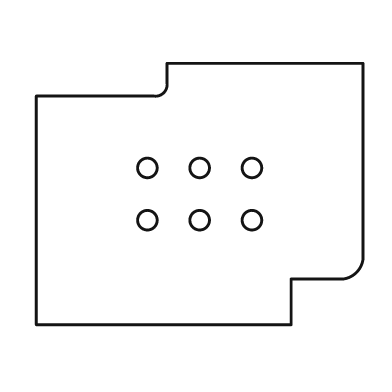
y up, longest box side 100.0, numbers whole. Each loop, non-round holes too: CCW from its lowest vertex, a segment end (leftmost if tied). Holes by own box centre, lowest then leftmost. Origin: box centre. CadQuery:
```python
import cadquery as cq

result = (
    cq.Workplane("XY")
    .moveTo(-50.0, -40.0)
    .lineTo(28.0, -40.0)
    .lineTo(28.0, -26.0)
    .lineTo(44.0, -26.0)
    .threePointArc((48.0, -24.0), (50.0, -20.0))
    .lineTo(50.0, 40.0)
    .lineTo(-10.0, 40.0)
    .lineTo(-10.0, 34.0)
    .threePointArc((-11.0, 31.0), (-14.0, 30.0))
    .lineTo(-50.0, 30.0)
    .close()
    .moveTo(-16.0, -8.0)
    .circle(3.0)
    .moveTo(0.0, -8.0)
    .circle(3.0)
    .moveTo(16.0, -8.0)
    .circle(3.0)
    .moveTo(-16.0, 8.0)
    .circle(3.0)
    .moveTo(0.0, 8.0)
    .circle(3.0)
    .moveTo(16.0, 8.0)
    .circle(3.0)
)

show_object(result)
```